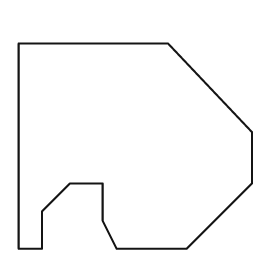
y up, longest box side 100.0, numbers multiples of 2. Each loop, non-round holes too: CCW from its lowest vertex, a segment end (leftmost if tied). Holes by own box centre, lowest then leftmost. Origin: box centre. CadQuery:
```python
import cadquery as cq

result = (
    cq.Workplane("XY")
    .moveTo(-50.0, -44.0)
    .lineTo(-40.0, -44.0)
    .lineTo(-40.0, -28.0)
    .lineTo(-28.0, -16.0)
    .lineTo(-14.0, -16.0)
    .lineTo(-14.0, -32.0)
    .lineTo(-8.0, -44.0)
    .lineTo(22.0, -44.0)
    .lineTo(50.0, -16.0)
    .lineTo(50.0, 6.0)
    .lineTo(14.0, 44.0)
    .lineTo(-50.0, 44.0)
    .close()
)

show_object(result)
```